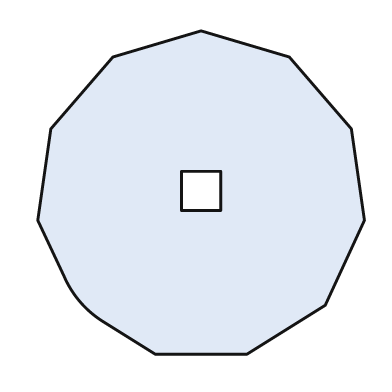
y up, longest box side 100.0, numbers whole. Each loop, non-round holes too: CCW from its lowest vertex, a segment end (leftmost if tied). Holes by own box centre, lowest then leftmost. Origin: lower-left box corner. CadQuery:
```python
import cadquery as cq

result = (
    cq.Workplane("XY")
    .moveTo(36.0, 0.0)
    .lineTo(64.0, 0.0)
    .lineTo(88.0, 15.0)
    .lineTo(100.0, 41.0)
    .lineTo(96.0, 69.0)
    .lineTo(77.0, 91.0)
    .lineTo(50.0, 99.0)
    .lineTo(23.0, 91.0)
    .lineTo(4.0, 69.0)
    .lineTo(0.0, 41.0)
    .lineTo(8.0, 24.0)
    .threePointArc((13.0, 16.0), (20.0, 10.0))
    .close()
    .moveTo(44.0, 44.0)
    .lineTo(56.0, 44.0)
    .lineTo(56.0, 56.0)
    .lineTo(44.0, 56.0)
    .close()
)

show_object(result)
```